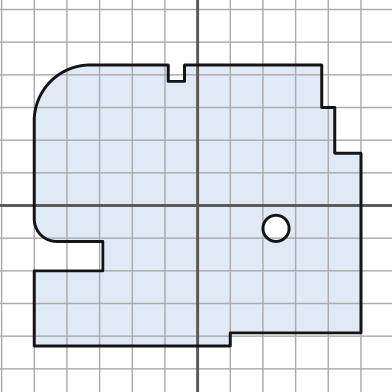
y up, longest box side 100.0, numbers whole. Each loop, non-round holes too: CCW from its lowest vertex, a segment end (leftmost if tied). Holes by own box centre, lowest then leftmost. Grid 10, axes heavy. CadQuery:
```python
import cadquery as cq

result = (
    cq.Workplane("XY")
    .moveTo(-50.0, -43.0)
    .lineTo(10.0, -43.0)
    .lineTo(10.0, -39.0)
    .lineTo(50.0, -39.0)
    .lineTo(50.0, 16.0)
    .lineTo(42.0, 16.0)
    .lineTo(42.0, 30.0)
    .lineTo(38.0, 30.0)
    .lineTo(38.0, 43.0)
    .lineTo(-4.0, 43.0)
    .lineTo(-4.0, 38.0)
    .lineTo(-9.0, 38.0)
    .lineTo(-9.0, 43.0)
    .lineTo(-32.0, 43.0)
    .threePointArc((-45.0, 38.0), (-50.0, 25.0))
    .lineTo(-50.0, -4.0)
    .threePointArc((-48.0, -9.0), (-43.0, -11.0))
    .lineTo(-29.0, -11.0)
    .lineTo(-29.0, -20.0)
    .lineTo(-50.0, -20.0)
    .close()
    .moveTo(24.0, -7.0)
    .circle(4.0)
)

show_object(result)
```